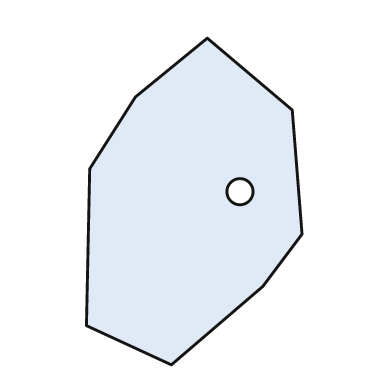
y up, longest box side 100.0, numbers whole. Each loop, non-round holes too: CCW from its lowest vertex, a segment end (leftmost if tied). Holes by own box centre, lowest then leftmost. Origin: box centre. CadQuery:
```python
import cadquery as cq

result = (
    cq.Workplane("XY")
    .moveTo(-7.0, -50.0)
    .lineTo(21.0, -26.0)
    .lineTo(33.0, -10.0)
    .lineTo(30.0, 28.0)
    .lineTo(4.0, 50.0)
    .lineTo(-18.0, 32.0)
    .lineTo(-32.0, 10.0)
    .lineTo(-33.0, -38.0)
    .close()
    .moveTo(14.0, 3.0)
    .circle(4.0)
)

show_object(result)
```